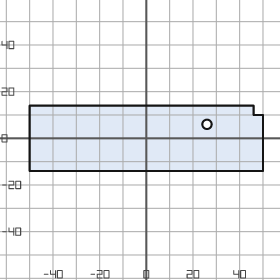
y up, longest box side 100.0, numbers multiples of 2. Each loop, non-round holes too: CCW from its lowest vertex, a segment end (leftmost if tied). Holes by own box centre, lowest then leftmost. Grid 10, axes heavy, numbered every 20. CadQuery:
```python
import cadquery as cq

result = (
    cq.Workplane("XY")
    .moveTo(-50.0, -14.0)
    .lineTo(50.0, -14.0)
    .lineTo(50.0, 10.0)
    .lineTo(46.0, 10.0)
    .lineTo(46.0, 14.0)
    .lineTo(-50.0, 14.0)
    .close()
    .moveTo(26.0, 6.0)
    .circle(2.0)
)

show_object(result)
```